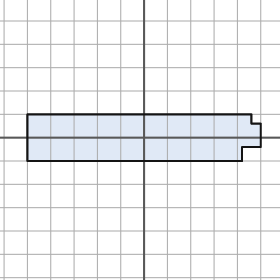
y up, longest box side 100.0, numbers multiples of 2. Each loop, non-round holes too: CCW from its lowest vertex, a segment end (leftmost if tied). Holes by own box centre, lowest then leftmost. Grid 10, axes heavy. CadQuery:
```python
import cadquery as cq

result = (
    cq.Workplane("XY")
    .moveTo(-50.0, -10.0)
    .lineTo(42.0, -10.0)
    .lineTo(42.0, -4.0)
    .lineTo(50.0, -4.0)
    .lineTo(50.0, 6.0)
    .lineTo(46.0, 6.0)
    .lineTo(46.0, 10.0)
    .lineTo(-50.0, 10.0)
    .close()
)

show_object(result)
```